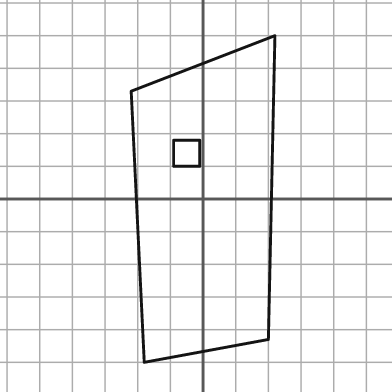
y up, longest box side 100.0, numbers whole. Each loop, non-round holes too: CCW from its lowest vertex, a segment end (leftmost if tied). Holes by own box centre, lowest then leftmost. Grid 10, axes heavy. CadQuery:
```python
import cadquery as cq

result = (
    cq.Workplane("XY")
    .moveTo(-18.0, -50.0)
    .lineTo(20.0, -43.0)
    .lineTo(22.0, 50.0)
    .lineTo(-22.0, 33.0)
    .close()
    .moveTo(-9.0, 10.0)
    .lineTo(-1.0, 10.0)
    .lineTo(-1.0, 18.0)
    .lineTo(-9.0, 18.0)
    .close()
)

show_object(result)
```